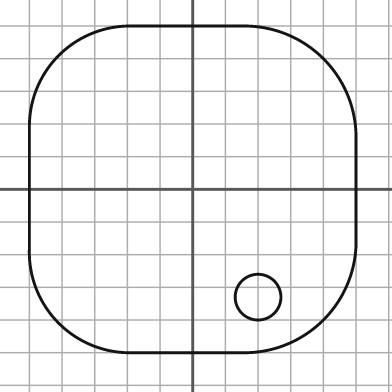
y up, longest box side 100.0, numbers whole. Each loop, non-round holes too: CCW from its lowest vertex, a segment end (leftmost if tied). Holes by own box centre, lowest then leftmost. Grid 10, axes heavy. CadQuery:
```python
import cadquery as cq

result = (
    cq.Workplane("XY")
    .moveTo(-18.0, -50.0)
    .lineTo(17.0, -50.0)
    .threePointArc((40.0, -40.0), (50.0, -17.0))
    .lineTo(50.0, 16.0)
    .threePointArc((40.0, 40.0), (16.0, 50.0))
    .lineTo(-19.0, 50.0)
    .threePointArc((-41.0, 41.0), (-50.0, 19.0))
    .lineTo(-50.0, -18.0)
    .threePointArc((-41.0, -41.0), (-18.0, -50.0))
    .close()
    .moveTo(20.0, -33.0)
    .circle(7.0)
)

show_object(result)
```